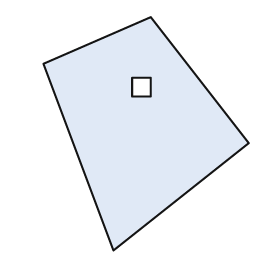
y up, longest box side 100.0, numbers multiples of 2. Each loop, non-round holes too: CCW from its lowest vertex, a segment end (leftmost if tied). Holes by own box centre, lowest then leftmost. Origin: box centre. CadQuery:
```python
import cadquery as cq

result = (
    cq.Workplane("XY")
    .moveTo(-14.0, -50.0)
    .lineTo(44.0, -4.0)
    .lineTo(2.0, 50.0)
    .lineTo(-44.0, 30.0)
    .close()
    .moveTo(-6.0, 16.0)
    .lineTo(2.0, 16.0)
    .lineTo(2.0, 24.0)
    .lineTo(-6.0, 24.0)
    .close()
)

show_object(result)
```